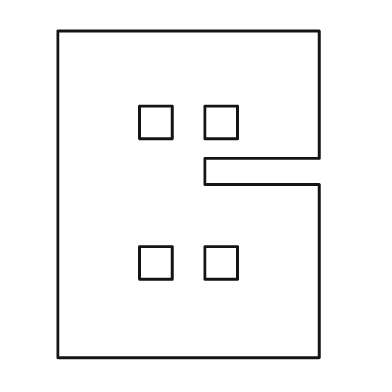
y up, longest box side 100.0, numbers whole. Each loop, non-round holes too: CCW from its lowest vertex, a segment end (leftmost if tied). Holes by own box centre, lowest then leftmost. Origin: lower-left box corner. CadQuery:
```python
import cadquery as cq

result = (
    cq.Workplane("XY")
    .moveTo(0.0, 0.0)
    .lineTo(80.0, 0.0)
    .lineTo(80.0, 53.0)
    .lineTo(45.0, 53.0)
    .lineTo(45.0, 61.0)
    .lineTo(80.0, 61.0)
    .lineTo(80.0, 100.0)
    .lineTo(0.0, 100.0)
    .close()
    .moveTo(25.0, 24.0)
    .lineTo(35.0, 24.0)
    .lineTo(35.0, 34.0)
    .lineTo(25.0, 34.0)
    .close()
    .moveTo(45.0, 24.0)
    .lineTo(55.0, 24.0)
    .lineTo(55.0, 34.0)
    .lineTo(45.0, 34.0)
    .close()
    .moveTo(25.0, 67.0)
    .lineTo(35.0, 67.0)
    .lineTo(35.0, 77.0)
    .lineTo(25.0, 77.0)
    .close()
    .moveTo(45.0, 67.0)
    .lineTo(55.0, 67.0)
    .lineTo(55.0, 77.0)
    .lineTo(45.0, 77.0)
    .close()
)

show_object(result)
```